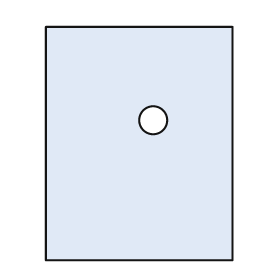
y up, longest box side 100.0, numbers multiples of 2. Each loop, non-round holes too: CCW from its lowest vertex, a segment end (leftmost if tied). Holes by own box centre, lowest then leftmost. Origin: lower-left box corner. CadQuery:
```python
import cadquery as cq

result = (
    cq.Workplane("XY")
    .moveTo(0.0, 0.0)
    .lineTo(80.0, 0.0)
    .lineTo(80.0, 100.0)
    .lineTo(0.0, 100.0)
    .close()
    .moveTo(46.0, 60.0)
    .circle(6.0)
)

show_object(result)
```